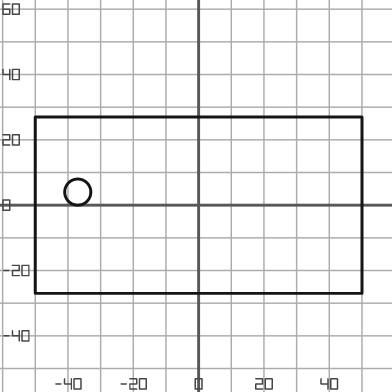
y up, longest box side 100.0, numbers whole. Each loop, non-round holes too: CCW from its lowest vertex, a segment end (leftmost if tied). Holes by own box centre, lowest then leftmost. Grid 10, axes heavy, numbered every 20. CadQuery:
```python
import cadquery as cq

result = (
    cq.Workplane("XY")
    .moveTo(-50.0, -27.0)
    .lineTo(50.0, -27.0)
    .lineTo(50.0, 27.0)
    .lineTo(-50.0, 27.0)
    .close()
    .moveTo(-37.0, 4.0)
    .circle(4.0)
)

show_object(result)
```